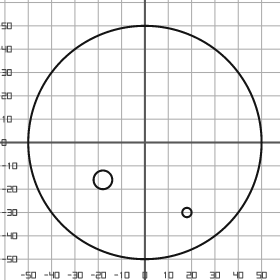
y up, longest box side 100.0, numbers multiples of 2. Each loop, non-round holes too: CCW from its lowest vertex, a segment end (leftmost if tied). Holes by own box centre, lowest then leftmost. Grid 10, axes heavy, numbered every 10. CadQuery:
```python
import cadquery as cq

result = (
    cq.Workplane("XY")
    .moveTo(0.0, 0.0)
    .circle(50.0)
    .moveTo(18.0, -30.0)
    .circle(2.0)
    .moveTo(-18.0, -16.0)
    .circle(4.0)
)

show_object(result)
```